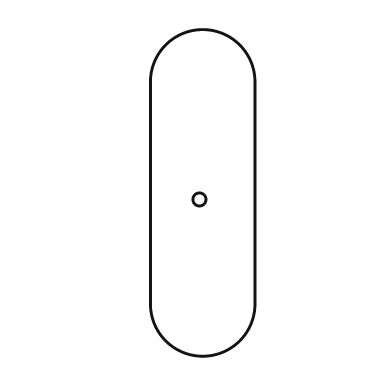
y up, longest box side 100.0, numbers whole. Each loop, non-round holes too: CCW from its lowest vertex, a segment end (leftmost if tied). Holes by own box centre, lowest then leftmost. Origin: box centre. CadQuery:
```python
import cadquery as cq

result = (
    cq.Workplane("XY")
    .moveTo(-16.0, -34.0)
    .threePointArc((0.0, -50.0), (16.0, -34.0))
    .lineTo(16.0, 34.0)
    .threePointArc((0.0, 50.0), (-16.0, 34.0))
    .close()
    .moveTo(-1.0, -2.0)
    .circle(2.0)
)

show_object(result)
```